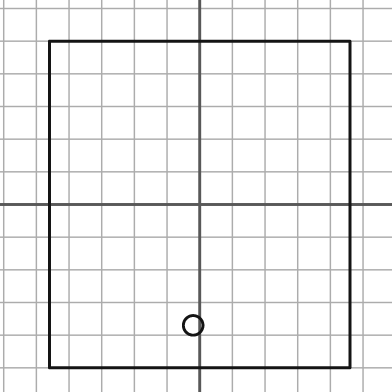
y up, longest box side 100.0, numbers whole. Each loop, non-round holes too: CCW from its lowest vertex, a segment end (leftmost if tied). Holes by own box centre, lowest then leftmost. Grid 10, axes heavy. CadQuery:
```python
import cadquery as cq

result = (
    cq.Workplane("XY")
    .moveTo(-46.0, -50.0)
    .lineTo(46.0, -50.0)
    .lineTo(46.0, 50.0)
    .lineTo(-46.0, 50.0)
    .close()
    .moveTo(-2.0, -37.0)
    .circle(3.0)
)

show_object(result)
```